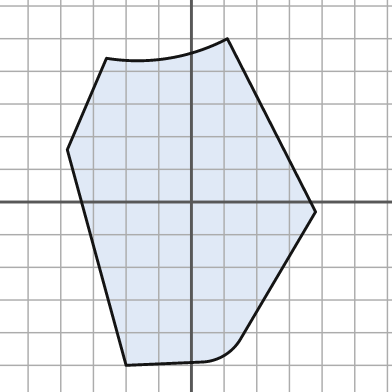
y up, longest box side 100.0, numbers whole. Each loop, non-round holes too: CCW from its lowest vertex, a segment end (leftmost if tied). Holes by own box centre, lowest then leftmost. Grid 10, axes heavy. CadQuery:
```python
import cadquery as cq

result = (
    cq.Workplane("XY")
    .moveTo(-20.0, -50.0)
    .lineTo(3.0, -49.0)
    .threePointArc((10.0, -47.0), (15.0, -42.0))
    .lineTo(38.0, -3.0)
    .lineTo(11.0, 50.0)
    .threePointArc((-7.0, 44.0), (-26.0, 44.0))
    .lineTo(-38.0, 16.0)
    .close()
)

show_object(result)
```